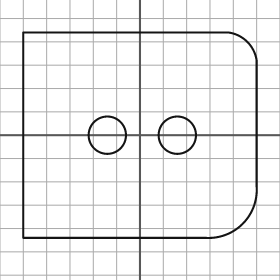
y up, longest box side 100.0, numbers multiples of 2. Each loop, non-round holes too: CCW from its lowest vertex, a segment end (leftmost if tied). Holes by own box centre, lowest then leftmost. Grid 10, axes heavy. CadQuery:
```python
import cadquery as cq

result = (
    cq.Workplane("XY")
    .moveTo(-50.0, -44.0)
    .lineTo(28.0, -44.0)
    .threePointArc((44.0, -38.0), (50.0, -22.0))
    .lineTo(50.0, 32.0)
    .threePointArc((46.0, 40.0), (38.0, 44.0))
    .lineTo(-50.0, 44.0)
    .close()
    .moveTo(-14.0, 0.0)
    .circle(8.0)
    .moveTo(16.0, 0.0)
    .circle(8.0)
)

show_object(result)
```